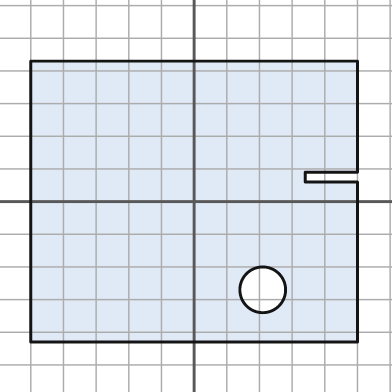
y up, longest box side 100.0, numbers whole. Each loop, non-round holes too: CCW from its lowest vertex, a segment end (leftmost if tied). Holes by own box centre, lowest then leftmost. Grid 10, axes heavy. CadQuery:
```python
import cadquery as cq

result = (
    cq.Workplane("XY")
    .moveTo(-50.0, -43.0)
    .lineTo(50.0, -43.0)
    .lineTo(50.0, 6.0)
    .lineTo(34.0, 6.0)
    .lineTo(34.0, 9.0)
    .lineTo(50.0, 9.0)
    .lineTo(50.0, 43.0)
    .lineTo(-50.0, 43.0)
    .close()
    .moveTo(21.0, -27.0)
    .circle(7.0)
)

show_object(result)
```